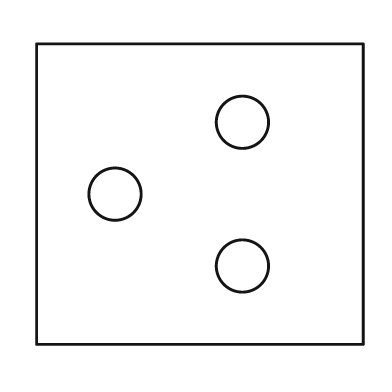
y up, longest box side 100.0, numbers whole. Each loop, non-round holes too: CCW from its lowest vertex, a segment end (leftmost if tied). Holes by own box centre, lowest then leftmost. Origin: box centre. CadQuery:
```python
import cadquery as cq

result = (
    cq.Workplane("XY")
    .moveTo(-50.0, -46.0)
    .lineTo(50.0, -46.0)
    .lineTo(50.0, 46.0)
    .lineTo(-50.0, 46.0)
    .close()
    .moveTo(13.0, -22.0)
    .circle(8.0)
    .moveTo(-26.0, 0.0)
    .circle(8.0)
    .moveTo(13.0, 22.0)
    .circle(8.0)
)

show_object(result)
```